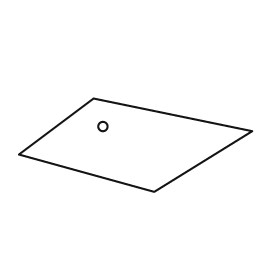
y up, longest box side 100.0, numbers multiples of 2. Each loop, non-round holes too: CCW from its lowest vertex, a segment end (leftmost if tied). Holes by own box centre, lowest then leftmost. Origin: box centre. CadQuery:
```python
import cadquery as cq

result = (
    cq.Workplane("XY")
    .moveTo(8.0, -20.0)
    .lineTo(50.0, 6.0)
    .lineTo(-18.0, 20.0)
    .lineTo(-50.0, -4.0)
    .close()
    .moveTo(-14.0, 8.0)
    .circle(2.0)
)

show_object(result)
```